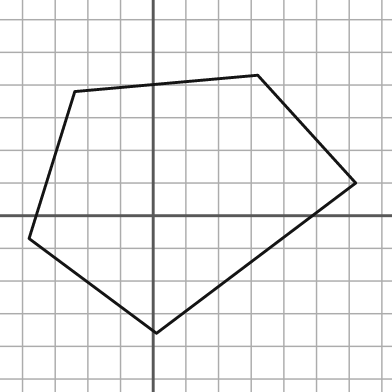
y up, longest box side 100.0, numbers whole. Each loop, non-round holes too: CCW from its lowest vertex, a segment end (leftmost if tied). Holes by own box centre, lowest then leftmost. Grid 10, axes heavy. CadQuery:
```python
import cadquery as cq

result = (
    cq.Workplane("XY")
    .moveTo(1.0, -36.0)
    .lineTo(62.0, 10.0)
    .lineTo(32.0, 43.0)
    .lineTo(-24.0, 38.0)
    .lineTo(-38.0, -7.0)
    .close()
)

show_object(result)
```